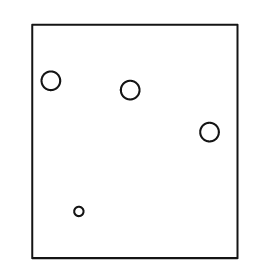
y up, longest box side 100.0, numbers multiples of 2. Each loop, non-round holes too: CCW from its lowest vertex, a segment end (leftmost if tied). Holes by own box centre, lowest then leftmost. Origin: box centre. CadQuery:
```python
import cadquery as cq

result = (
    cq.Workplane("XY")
    .moveTo(-44.0, -50.0)
    .lineTo(44.0, -50.0)
    .lineTo(44.0, 50.0)
    .lineTo(-44.0, 50.0)
    .close()
    .moveTo(-24.0, -30.0)
    .circle(2.0)
    .moveTo(32.0, 4.0)
    .circle(4.0)
    .moveTo(-2.0, 22.0)
    .circle(4.0)
    .moveTo(-36.0, 26.0)
    .circle(4.0)
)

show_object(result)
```